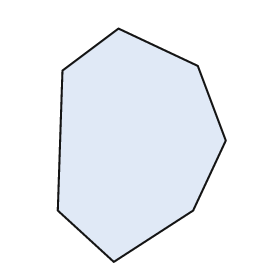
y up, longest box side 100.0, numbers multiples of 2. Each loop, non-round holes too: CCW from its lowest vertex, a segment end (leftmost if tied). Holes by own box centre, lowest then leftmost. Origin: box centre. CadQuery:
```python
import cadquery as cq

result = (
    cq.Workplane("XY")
    .moveTo(-12.0, -50.0)
    .lineTo(22.0, -28.0)
    .lineTo(36.0, 2.0)
    .lineTo(24.0, 34.0)
    .lineTo(-10.0, 50.0)
    .lineTo(-34.0, 32.0)
    .lineTo(-36.0, -28.0)
    .close()
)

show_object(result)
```